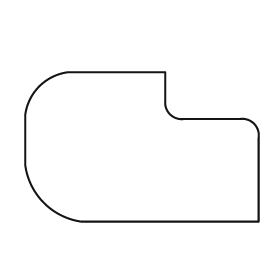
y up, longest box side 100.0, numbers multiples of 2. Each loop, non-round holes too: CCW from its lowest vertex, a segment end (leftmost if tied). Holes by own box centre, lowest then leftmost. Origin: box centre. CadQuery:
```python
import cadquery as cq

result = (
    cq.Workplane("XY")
    .moveTo(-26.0, -32.0)
    .lineTo(50.0, -32.0)
    .lineTo(50.0, 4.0)
    .threePointArc((48.0, 10.0), (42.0, 12.0))
    .lineTo(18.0, 12.0)
    .threePointArc((12.0, 14.0), (10.0, 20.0))
    .lineTo(10.0, 32.0)
    .lineTo(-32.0, 32.0)
    .threePointArc((-44.0, 26.0), (-50.0, 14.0))
    .lineTo(-50.0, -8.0)
    .threePointArc((-42.0, -24.0), (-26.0, -32.0))
    .close()
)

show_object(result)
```